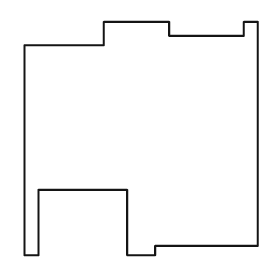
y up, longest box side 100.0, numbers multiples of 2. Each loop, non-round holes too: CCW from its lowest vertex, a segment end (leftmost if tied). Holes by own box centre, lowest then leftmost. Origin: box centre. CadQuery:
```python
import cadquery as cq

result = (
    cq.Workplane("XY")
    .moveTo(-50.0, -50.0)
    .lineTo(-44.0, -50.0)
    .lineTo(-44.0, -22.0)
    .lineTo(-6.0, -22.0)
    .lineTo(-6.0, -50.0)
    .lineTo(6.0, -50.0)
    .lineTo(6.0, -46.0)
    .lineTo(50.0, -46.0)
    .lineTo(50.0, 50.0)
    .lineTo(44.0, 50.0)
    .lineTo(44.0, 44.0)
    .lineTo(12.0, 44.0)
    .lineTo(12.0, 50.0)
    .lineTo(-16.0, 50.0)
    .lineTo(-16.0, 40.0)
    .lineTo(-50.0, 40.0)
    .close()
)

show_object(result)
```